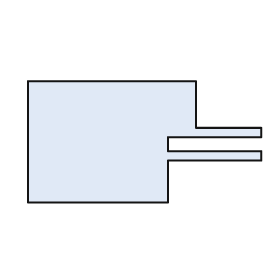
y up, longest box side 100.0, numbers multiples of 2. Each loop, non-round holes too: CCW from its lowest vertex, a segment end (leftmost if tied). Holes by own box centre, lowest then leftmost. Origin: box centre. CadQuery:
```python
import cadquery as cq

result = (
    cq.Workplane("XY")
    .moveTo(-50.0, -26.0)
    .lineTo(10.0, -26.0)
    .lineTo(10.0, -8.0)
    .lineTo(50.0, -8.0)
    .lineTo(50.0, -4.0)
    .lineTo(10.0, -4.0)
    .lineTo(10.0, 2.0)
    .lineTo(50.0, 2.0)
    .lineTo(50.0, 6.0)
    .lineTo(22.0, 6.0)
    .lineTo(22.0, 26.0)
    .lineTo(-50.0, 26.0)
    .close()
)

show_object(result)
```